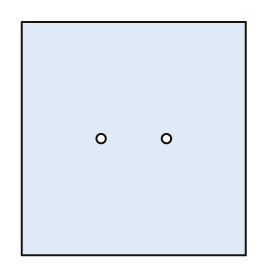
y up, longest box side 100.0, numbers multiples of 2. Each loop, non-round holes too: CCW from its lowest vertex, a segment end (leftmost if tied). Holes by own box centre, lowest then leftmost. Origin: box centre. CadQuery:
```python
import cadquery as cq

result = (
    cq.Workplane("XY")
    .moveTo(-48.0, -50.0)
    .lineTo(48.0, -50.0)
    .lineTo(48.0, 50.0)
    .lineTo(-48.0, 50.0)
    .close()
    .moveTo(-14.0, 0.0)
    .circle(2.0)
    .moveTo(14.0, 0.0)
    .circle(2.0)
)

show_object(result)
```